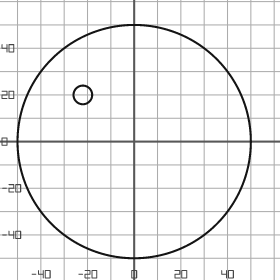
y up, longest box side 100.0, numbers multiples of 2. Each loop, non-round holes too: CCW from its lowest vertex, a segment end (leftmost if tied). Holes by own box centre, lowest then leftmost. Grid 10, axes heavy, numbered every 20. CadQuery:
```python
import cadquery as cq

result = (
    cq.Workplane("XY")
    .moveTo(0.0, 0.0)
    .circle(50.0)
    .moveTo(-22.0, 20.0)
    .circle(4.0)
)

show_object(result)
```